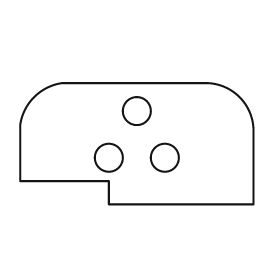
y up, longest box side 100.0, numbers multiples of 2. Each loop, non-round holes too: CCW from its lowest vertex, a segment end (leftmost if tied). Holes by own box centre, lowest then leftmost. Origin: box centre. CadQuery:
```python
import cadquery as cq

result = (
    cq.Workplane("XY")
    .moveTo(-12.0, -26.0)
    .lineTo(50.0, -26.0)
    .lineTo(50.0, 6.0)
    .threePointArc((44.0, 20.0), (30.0, 26.0))
    .lineTo(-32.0, 26.0)
    .threePointArc((-44.0, 20.0), (-50.0, 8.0))
    .lineTo(-50.0, -16.0)
    .lineTo(-12.0, -16.0)
    .close()
    .moveTo(-12.0, -6.0)
    .circle(6.0)
    .moveTo(12.0, -6.0)
    .circle(6.0)
    .moveTo(0.0, 14.0)
    .circle(6.0)
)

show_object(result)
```